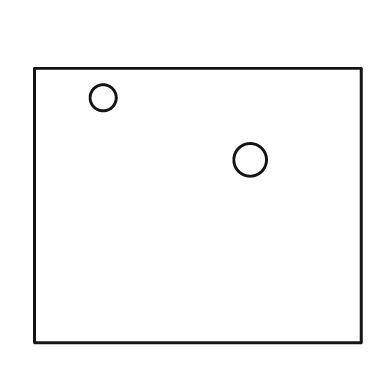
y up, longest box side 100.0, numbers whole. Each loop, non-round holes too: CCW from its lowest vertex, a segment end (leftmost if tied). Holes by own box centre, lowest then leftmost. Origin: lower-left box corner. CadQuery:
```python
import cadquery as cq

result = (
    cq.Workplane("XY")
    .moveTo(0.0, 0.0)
    .lineTo(100.0, 0.0)
    .lineTo(100.0, 84.0)
    .lineTo(0.0, 84.0)
    .close()
    .moveTo(66.0, 56.0)
    .circle(5.0)
    .moveTo(21.0, 75.0)
    .circle(4.0)
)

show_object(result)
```